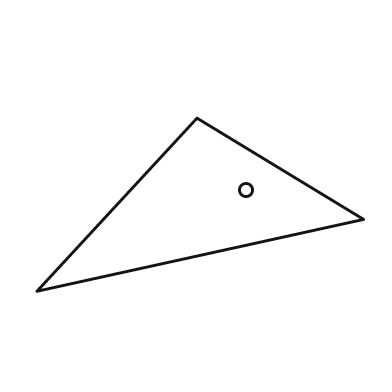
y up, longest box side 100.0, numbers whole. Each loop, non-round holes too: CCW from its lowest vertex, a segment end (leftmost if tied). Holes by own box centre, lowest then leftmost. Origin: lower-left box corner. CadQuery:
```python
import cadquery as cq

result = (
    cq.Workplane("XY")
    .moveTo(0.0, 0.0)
    .lineTo(100.0, 22.0)
    .lineTo(49.0, 53.0)
    .close()
    .moveTo(64.0, 31.0)
    .circle(2.0)
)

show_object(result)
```